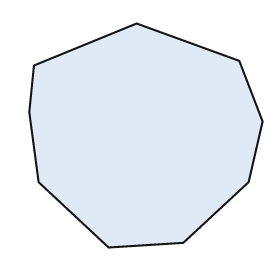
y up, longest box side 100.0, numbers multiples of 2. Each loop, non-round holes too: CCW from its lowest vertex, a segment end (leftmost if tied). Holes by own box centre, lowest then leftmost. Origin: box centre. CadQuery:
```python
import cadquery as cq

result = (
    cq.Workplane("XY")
    .moveTo(-16.0, -48.0)
    .lineTo(16.0, -46.0)
    .lineTo(44.0, -20.0)
    .lineTo(50.0, 6.0)
    .lineTo(40.0, 32.0)
    .lineTo(-4.0, 48.0)
    .lineTo(-48.0, 30.0)
    .lineTo(-50.0, 10.0)
    .lineTo(-46.0, -20.0)
    .close()
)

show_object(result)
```